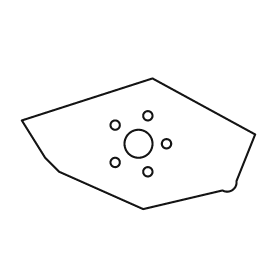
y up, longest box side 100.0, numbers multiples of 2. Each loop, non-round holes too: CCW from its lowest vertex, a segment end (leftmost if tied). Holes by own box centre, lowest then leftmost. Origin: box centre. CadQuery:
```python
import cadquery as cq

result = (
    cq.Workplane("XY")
    .moveTo(2.0, -28.0)
    .lineTo(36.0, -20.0)
    .threePointArc((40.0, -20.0), (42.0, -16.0))
    .lineTo(50.0, 4.0)
    .lineTo(6.0, 28.0)
    .lineTo(-50.0, 10.0)
    .lineTo(-40.0, -6.0)
    .lineTo(-34.0, -12.0)
    .close()
    .moveTo(4.0, -12.0)
    .circle(2.0)
    .moveTo(-10.0, -8.0)
    .circle(2.0)
    .moveTo(0.0, 0.0)
    .circle(6.0)
    .moveTo(12.0, 0.0)
    .circle(2.0)
    .moveTo(-10.0, 8.0)
    .circle(2.0)
    .moveTo(4.0, 12.0)
    .circle(2.0)
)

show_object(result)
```